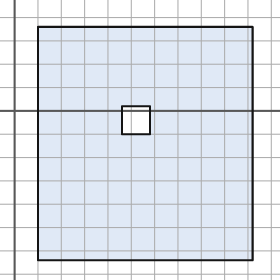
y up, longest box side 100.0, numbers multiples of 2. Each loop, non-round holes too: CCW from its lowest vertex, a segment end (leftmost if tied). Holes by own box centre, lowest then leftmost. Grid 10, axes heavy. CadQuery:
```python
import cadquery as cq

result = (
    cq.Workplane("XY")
    .moveTo(10.0, -64.0)
    .lineTo(102.0, -64.0)
    .lineTo(102.0, 36.0)
    .lineTo(10.0, 36.0)
    .close()
    .moveTo(46.0, -10.0)
    .lineTo(58.0, -10.0)
    .lineTo(58.0, 2.0)
    .lineTo(46.0, 2.0)
    .close()
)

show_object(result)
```